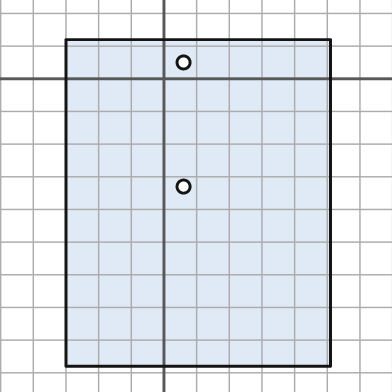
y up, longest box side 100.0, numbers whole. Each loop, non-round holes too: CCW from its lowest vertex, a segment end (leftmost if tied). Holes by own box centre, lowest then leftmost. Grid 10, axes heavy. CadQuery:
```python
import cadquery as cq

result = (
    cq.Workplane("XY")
    .moveTo(-30.0, -88.0)
    .lineTo(51.0, -88.0)
    .lineTo(51.0, 12.0)
    .lineTo(-30.0, 12.0)
    .close()
    .moveTo(6.0, -33.0)
    .circle(2.0)
    .moveTo(6.0, 5.0)
    .circle(2.0)
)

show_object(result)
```